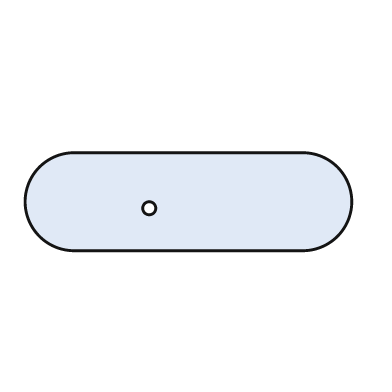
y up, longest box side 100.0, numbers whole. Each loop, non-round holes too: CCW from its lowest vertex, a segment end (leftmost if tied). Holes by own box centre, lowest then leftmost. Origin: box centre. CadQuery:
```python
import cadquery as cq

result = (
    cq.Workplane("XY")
    .moveTo(-35.0, -15.0)
    .lineTo(35.0, -15.0)
    .threePointArc((50.0, 0.0), (35.0, 15.0))
    .lineTo(-35.0, 15.0)
    .threePointArc((-50.0, 0.0), (-35.0, -15.0))
    .close()
    .moveTo(-12.0, -2.0)
    .circle(2.0)
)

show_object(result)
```